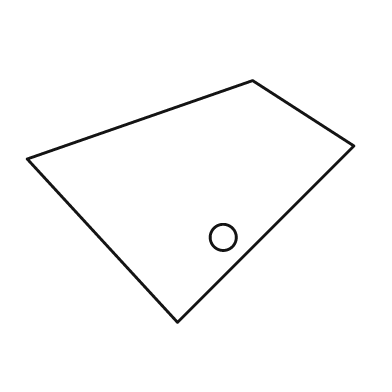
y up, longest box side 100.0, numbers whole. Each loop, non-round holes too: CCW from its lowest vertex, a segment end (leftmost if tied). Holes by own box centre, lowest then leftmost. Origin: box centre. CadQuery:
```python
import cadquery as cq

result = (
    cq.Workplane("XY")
    .moveTo(-4.0, -37.0)
    .lineTo(50.0, 17.0)
    .lineTo(19.0, 37.0)
    .lineTo(-50.0, 13.0)
    .close()
    .moveTo(10.0, -11.0)
    .circle(4.0)
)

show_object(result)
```